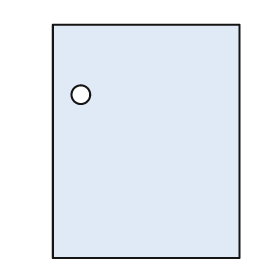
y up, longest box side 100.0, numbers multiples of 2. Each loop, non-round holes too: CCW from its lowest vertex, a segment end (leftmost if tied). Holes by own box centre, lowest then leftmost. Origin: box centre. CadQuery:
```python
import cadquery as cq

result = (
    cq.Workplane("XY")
    .moveTo(-40.0, -50.0)
    .lineTo(40.0, -50.0)
    .lineTo(40.0, 50.0)
    .lineTo(-40.0, 50.0)
    .close()
    .moveTo(-28.0, 20.0)
    .circle(4.0)
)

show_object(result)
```